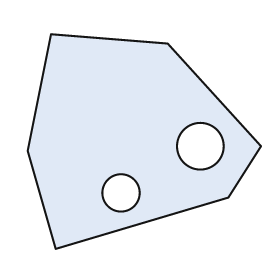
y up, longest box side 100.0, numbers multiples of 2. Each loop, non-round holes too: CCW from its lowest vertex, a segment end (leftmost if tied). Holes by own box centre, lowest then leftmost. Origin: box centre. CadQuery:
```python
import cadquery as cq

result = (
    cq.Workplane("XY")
    .moveTo(-38.0, -46.0)
    .lineTo(36.0, -24.0)
    .lineTo(50.0, -2.0)
    .lineTo(10.0, 42.0)
    .lineTo(-40.0, 46.0)
    .lineTo(-50.0, -4.0)
    .close()
    .moveTo(-10.0, -22.0)
    .circle(8.0)
    .moveTo(24.0, -2.0)
    .circle(10.0)
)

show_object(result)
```